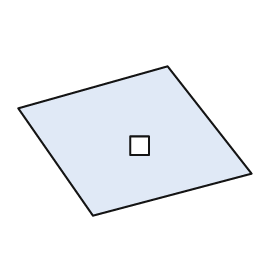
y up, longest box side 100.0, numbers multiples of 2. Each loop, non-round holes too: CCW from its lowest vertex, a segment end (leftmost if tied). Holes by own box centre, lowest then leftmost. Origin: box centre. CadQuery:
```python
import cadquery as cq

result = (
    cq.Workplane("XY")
    .moveTo(-18.0, -32.0)
    .lineTo(50.0, -14.0)
    .lineTo(14.0, 32.0)
    .lineTo(-50.0, 14.0)
    .close()
    .moveTo(-2.0, -6.0)
    .lineTo(6.0, -6.0)
    .lineTo(6.0, 2.0)
    .lineTo(-2.0, 2.0)
    .close()
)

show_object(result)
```